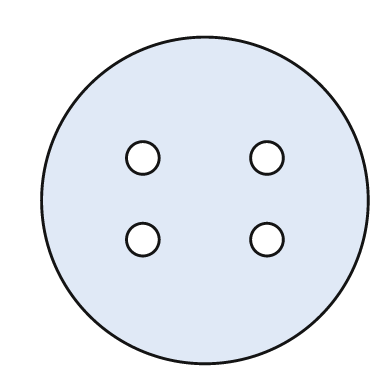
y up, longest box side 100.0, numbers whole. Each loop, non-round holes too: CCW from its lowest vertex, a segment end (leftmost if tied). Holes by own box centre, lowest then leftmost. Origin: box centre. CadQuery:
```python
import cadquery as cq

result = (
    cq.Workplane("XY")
    .moveTo(0.0, 0.0)
    .circle(50.0)
    .moveTo(-19.0, -12.0)
    .circle(5.0)
    .moveTo(19.0, -12.0)
    .circle(5.0)
    .moveTo(-19.0, 13.0)
    .circle(5.0)
    .moveTo(19.0, 13.0)
    .circle(5.0)
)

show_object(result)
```